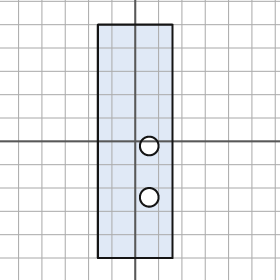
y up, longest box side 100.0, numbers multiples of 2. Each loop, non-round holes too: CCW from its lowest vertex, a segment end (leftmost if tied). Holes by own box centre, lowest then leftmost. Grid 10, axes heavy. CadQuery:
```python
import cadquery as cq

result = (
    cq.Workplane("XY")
    .moveTo(-16.0, -50.0)
    .lineTo(16.0, -50.0)
    .lineTo(16.0, 50.0)
    .lineTo(-16.0, 50.0)
    .close()
    .moveTo(6.0, -24.0)
    .circle(4.0)
    .moveTo(6.0, -2.0)
    .circle(4.0)
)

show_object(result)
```